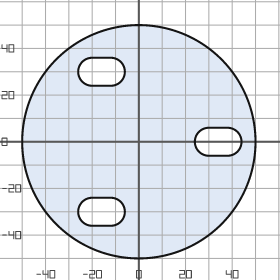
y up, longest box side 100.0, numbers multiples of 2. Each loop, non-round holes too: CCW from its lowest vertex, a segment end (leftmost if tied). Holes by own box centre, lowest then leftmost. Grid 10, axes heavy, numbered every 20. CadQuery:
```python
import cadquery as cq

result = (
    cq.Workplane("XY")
    .moveTo(0.0, 0.0)
    .circle(50.0)
    .moveTo(-20.0, -36.0)
    .lineTo(-12.0, -36.0)
    .threePointArc((-6.0, -30.0), (-12.0, -24.0))
    .lineTo(-20.0, -24.0)
    .threePointArc((-26.0, -30.0), (-20.0, -36.0))
    .close()
    .moveTo(30.0, -6.0)
    .lineTo(38.0, -6.0)
    .threePointArc((44.0, 0.0), (38.0, 6.0))
    .lineTo(30.0, 6.0)
    .threePointArc((24.0, 0.0), (30.0, -6.0))
    .close()
    .moveTo(-20.0, 24.0)
    .lineTo(-12.0, 24.0)
    .threePointArc((-6.0, 30.0), (-12.0, 36.0))
    .lineTo(-20.0, 36.0)
    .threePointArc((-26.0, 30.0), (-20.0, 24.0))
    .close()
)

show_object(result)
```